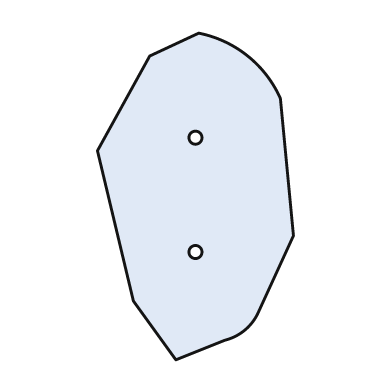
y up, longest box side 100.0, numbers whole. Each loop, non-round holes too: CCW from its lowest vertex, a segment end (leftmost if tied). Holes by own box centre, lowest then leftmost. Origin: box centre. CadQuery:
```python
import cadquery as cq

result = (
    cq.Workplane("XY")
    .moveTo(-6.0, -50.0)
    .lineTo(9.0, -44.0)
    .threePointArc((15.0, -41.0), (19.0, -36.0))
    .lineTo(30.0, -12.0)
    .lineTo(26.0, 30.0)
    .threePointArc((16.0, 43.0), (1.0, 50.0))
    .lineTo(-14.0, 43.0)
    .lineTo(-30.0, 14.0)
    .lineTo(-19.0, -32.0)
    .close()
    .moveTo(0.0, -17.0)
    .circle(2.0)
    .moveTo(0.0, 18.0)
    .circle(2.0)
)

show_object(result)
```